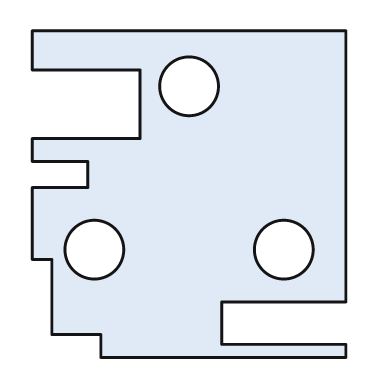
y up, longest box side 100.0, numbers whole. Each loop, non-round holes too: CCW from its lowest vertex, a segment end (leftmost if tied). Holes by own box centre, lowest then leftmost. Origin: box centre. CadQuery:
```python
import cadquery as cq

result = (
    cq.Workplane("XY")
    .moveTo(-27.0, -50.0)
    .lineTo(48.0, -50.0)
    .lineTo(48.0, -46.0)
    .lineTo(10.0, -46.0)
    .lineTo(10.0, -33.0)
    .lineTo(48.0, -33.0)
    .lineTo(48.0, 50.0)
    .lineTo(-48.0, 50.0)
    .lineTo(-48.0, 38.0)
    .lineTo(-15.0, 38.0)
    .lineTo(-15.0, 17.0)
    .lineTo(-48.0, 17.0)
    .lineTo(-48.0, 10.0)
    .lineTo(-31.0, 10.0)
    .lineTo(-31.0, 2.0)
    .lineTo(-48.0, 2.0)
    .lineTo(-48.0, -20.0)
    .lineTo(-42.0, -20.0)
    .lineTo(-42.0, -43.0)
    .lineTo(-27.0, -43.0)
    .close()
    .moveTo(-29.0, -17.0)
    .circle(9.0)
    .moveTo(29.0, -17.0)
    .circle(9.0)
    .moveTo(0.0, 33.0)
    .circle(9.0)
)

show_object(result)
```